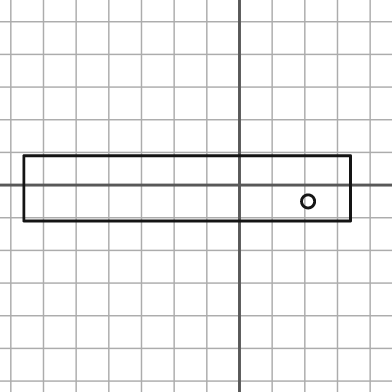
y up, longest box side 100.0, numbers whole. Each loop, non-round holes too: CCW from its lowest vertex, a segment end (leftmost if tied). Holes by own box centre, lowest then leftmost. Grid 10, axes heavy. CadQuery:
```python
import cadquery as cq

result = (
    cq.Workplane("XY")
    .moveTo(-66.0, -11.0)
    .lineTo(34.0, -11.0)
    .lineTo(34.0, 9.0)
    .lineTo(-66.0, 9.0)
    .close()
    .moveTo(21.0, -5.0)
    .circle(2.0)
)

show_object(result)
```